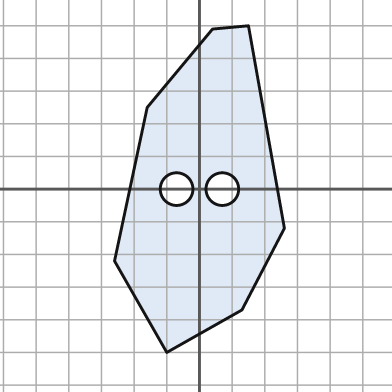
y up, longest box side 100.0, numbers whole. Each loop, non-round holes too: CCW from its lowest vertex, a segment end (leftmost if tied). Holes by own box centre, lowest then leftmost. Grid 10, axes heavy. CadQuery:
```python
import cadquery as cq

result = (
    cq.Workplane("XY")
    .moveTo(-10.0, -50.0)
    .lineTo(13.0, -37.0)
    .lineTo(26.0, -12.0)
    .lineTo(15.0, 50.0)
    .lineTo(4.0, 49.0)
    .lineTo(-16.0, 25.0)
    .lineTo(-26.0, -22.0)
    .close()
    .moveTo(-7.0, 0.0)
    .circle(5.0)
    .moveTo(7.0, 0.0)
    .circle(5.0)
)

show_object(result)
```